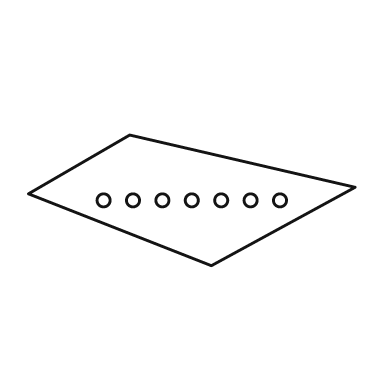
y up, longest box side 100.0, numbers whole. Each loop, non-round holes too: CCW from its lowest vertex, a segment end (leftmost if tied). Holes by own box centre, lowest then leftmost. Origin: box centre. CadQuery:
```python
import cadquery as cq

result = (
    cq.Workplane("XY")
    .moveTo(6.0, -20.0)
    .lineTo(50.0, 4.0)
    .lineTo(-19.0, 20.0)
    .lineTo(-50.0, 2.0)
    .close()
    .moveTo(-27.0, 0.0)
    .circle(2.0)
    .moveTo(-18.0, 0.0)
    .circle(2.0)
    .moveTo(-9.0, 0.0)
    .circle(2.0)
    .moveTo(0.0, 0.0)
    .circle(2.0)
    .moveTo(9.0, 0.0)
    .circle(2.0)
    .moveTo(18.0, 0.0)
    .circle(2.0)
    .moveTo(27.0, 0.0)
    .circle(2.0)
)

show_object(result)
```